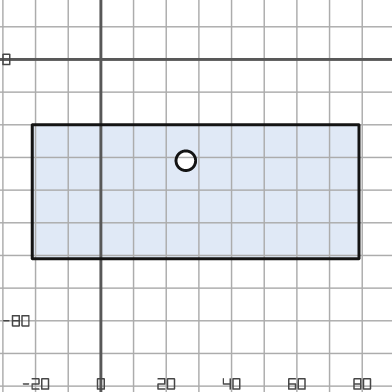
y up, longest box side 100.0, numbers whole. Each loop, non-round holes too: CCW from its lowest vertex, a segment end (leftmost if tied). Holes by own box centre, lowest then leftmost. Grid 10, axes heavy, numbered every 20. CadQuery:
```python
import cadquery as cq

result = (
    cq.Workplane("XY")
    .moveTo(-21.0, -61.0)
    .lineTo(79.0, -61.0)
    .lineTo(79.0, -20.0)
    .lineTo(-21.0, -20.0)
    .close()
    .moveTo(26.0, -31.0)
    .circle(3.0)
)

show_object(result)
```